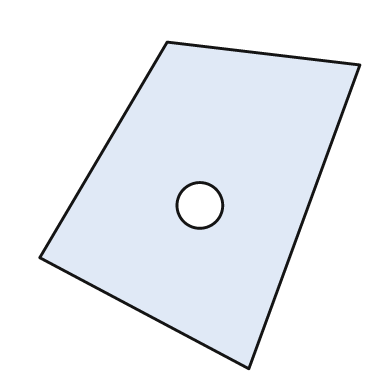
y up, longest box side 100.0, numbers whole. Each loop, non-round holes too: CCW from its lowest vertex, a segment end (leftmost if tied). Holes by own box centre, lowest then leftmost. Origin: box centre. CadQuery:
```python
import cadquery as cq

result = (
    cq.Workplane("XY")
    .moveTo(15.0, -50.0)
    .lineTo(49.0, 43.0)
    .lineTo(-10.0, 50.0)
    .lineTo(-49.0, -16.0)
    .close()
    .moveTo(0.0, 0.0)
    .circle(7.0)
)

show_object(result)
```